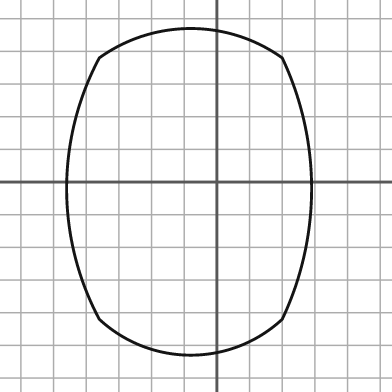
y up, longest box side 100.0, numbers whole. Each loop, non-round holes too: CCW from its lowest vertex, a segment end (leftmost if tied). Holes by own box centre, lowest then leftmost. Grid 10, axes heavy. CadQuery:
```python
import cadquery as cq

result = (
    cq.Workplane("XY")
    .moveTo(-36.0, -42.0)
    .threePointArc((-8.0, -53.0), (20.0, -42.0))
    .threePointArc((29.0, -2.0), (20.0, 38.0))
    .threePointArc((-8.0, 47.0), (-36.0, 38.0))
    .threePointArc((-46.0, -2.0), (-36.0, -42.0))
    .close()
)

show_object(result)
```